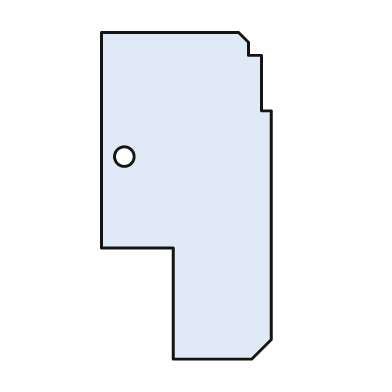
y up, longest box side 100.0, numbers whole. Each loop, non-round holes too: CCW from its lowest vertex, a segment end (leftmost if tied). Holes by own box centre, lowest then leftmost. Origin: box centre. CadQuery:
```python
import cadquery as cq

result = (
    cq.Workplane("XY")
    .moveTo(-4.0, -50.0)
    .lineTo(20.0, -50.0)
    .lineTo(26.0, -44.0)
    .lineTo(26.0, 26.0)
    .lineTo(23.0, 26.0)
    .lineTo(23.0, 43.0)
    .lineTo(19.0, 43.0)
    .lineTo(19.0, 47.0)
    .lineTo(16.0, 50.0)
    .lineTo(-26.0, 50.0)
    .lineTo(-26.0, -16.0)
    .lineTo(-4.0, -16.0)
    .close()
    .moveTo(-19.0, 12.0)
    .circle(3.0)
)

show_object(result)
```